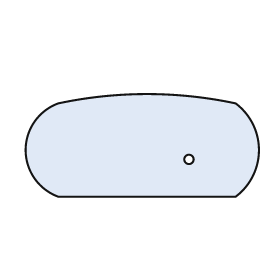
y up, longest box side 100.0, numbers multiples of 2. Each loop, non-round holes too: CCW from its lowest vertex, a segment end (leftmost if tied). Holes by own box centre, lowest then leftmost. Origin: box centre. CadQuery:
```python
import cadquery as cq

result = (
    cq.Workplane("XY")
    .moveTo(-36.0, -22.0)
    .lineTo(40.0, -22.0)
    .threePointArc((50.0, -2.0), (40.0, 18.0))
    .threePointArc((2.0, 22.0), (-36.0, 18.0))
    .threePointArc((-50.0, -2.0), (-36.0, -22.0))
    .close()
    .moveTo(20.0, -6.0)
    .circle(2.0)
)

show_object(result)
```